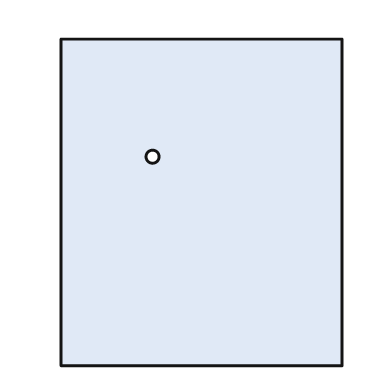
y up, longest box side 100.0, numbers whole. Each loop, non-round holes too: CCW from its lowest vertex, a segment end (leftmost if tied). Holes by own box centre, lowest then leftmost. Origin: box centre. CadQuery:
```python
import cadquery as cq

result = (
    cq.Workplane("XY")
    .moveTo(-43.0, -50.0)
    .lineTo(43.0, -50.0)
    .lineTo(43.0, 50.0)
    .lineTo(-43.0, 50.0)
    .close()
    .moveTo(-15.0, 14.0)
    .circle(2.0)
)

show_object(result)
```